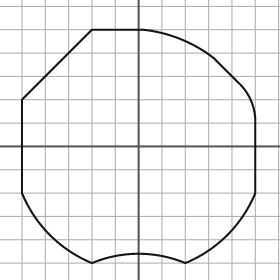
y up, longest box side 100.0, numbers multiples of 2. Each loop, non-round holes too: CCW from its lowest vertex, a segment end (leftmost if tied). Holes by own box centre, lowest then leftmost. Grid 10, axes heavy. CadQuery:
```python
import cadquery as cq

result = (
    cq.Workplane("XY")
    .moveTo(-20.0, -50.0)
    .threePointArc((0.0, -46.0), (20.0, -50.0))
    .threePointArc((38.0, -38.0), (50.0, -20.0))
    .lineTo(50.0, 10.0)
    .threePointArc((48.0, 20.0), (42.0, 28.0))
    .lineTo(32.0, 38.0)
    .threePointArc((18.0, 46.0), (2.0, 50.0))
    .lineTo(-20.0, 50.0)
    .lineTo(-50.0, 20.0)
    .lineTo(-50.0, -20.0)
    .threePointArc((-38.0, -38.0), (-20.0, -50.0))
    .close()
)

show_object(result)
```